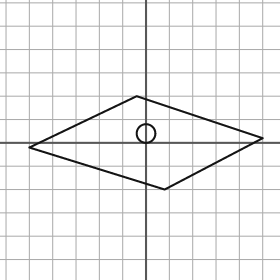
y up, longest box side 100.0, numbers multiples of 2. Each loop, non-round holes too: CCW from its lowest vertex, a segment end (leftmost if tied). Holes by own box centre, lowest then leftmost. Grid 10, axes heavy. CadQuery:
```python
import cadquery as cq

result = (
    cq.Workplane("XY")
    .moveTo(8.0, -20.0)
    .lineTo(50.0, 2.0)
    .lineTo(-4.0, 20.0)
    .lineTo(-50.0, -2.0)
    .close()
    .moveTo(0.0, 4.0)
    .circle(4.0)
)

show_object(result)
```